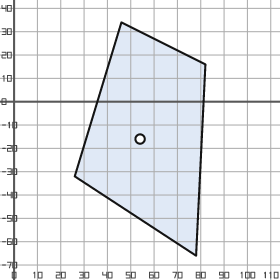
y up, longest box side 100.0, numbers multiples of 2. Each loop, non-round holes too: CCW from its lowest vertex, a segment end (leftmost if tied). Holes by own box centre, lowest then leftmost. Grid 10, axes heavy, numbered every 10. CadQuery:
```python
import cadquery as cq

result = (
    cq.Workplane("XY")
    .moveTo(78.0, -66.0)
    .lineTo(82.0, 16.0)
    .lineTo(46.0, 34.0)
    .lineTo(26.0, -32.0)
    .close()
    .moveTo(54.0, -16.0)
    .circle(2.0)
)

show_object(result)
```